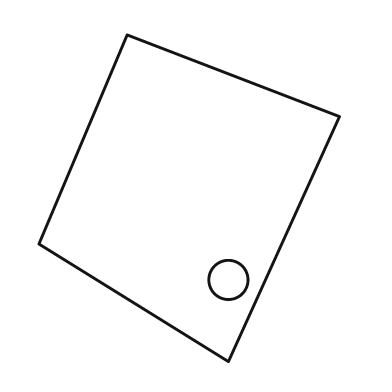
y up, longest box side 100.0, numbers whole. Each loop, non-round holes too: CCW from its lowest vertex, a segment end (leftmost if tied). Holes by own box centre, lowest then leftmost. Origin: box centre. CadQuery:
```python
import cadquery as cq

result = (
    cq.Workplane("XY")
    .moveTo(12.0, -50.0)
    .lineTo(46.0, 25.0)
    .lineTo(-19.0, 50.0)
    .lineTo(-46.0, -14.0)
    .close()
    .moveTo(12.0, -25.0)
    .circle(6.0)
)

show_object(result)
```